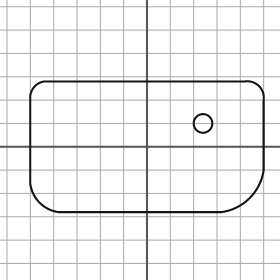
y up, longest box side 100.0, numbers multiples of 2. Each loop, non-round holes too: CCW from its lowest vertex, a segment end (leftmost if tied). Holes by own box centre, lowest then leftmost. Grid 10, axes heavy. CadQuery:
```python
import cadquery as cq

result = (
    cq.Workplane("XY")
    .moveTo(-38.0, -28.0)
    .lineTo(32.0, -28.0)
    .threePointArc((44.0, -22.0), (50.0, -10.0))
    .lineTo(50.0, 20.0)
    .threePointArc((48.0, 26.0), (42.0, 28.0))
    .lineTo(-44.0, 28.0)
    .threePointArc((-48.0, 26.0), (-50.0, 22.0))
    .lineTo(-50.0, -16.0)
    .threePointArc((-46.0, -24.0), (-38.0, -28.0))
    .close()
    .moveTo(24.0, 10.0)
    .circle(4.0)
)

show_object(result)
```